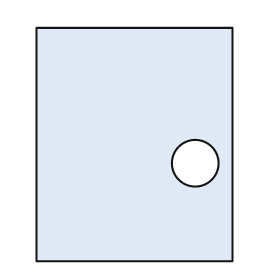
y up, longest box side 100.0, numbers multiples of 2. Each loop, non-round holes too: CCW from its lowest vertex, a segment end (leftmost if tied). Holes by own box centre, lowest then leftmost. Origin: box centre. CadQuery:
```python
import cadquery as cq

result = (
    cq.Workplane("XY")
    .moveTo(-42.0, -50.0)
    .lineTo(42.0, -50.0)
    .lineTo(42.0, 50.0)
    .lineTo(-42.0, 50.0)
    .close()
    .moveTo(26.0, -8.0)
    .circle(10.0)
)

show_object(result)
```